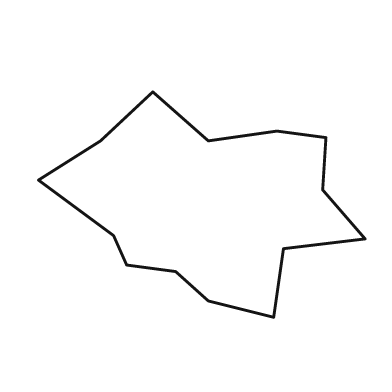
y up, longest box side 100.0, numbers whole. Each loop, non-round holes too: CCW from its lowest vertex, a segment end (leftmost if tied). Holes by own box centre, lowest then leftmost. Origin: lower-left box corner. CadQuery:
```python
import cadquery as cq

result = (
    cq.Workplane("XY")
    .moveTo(72.0, 0.0)
    .lineTo(75.0, 21.0)
    .lineTo(100.0, 24.0)
    .lineTo(87.0, 39.0)
    .lineTo(88.0, 55.0)
    .lineTo(73.0, 57.0)
    .lineTo(52.0, 54.0)
    .lineTo(35.0, 69.0)
    .lineTo(19.0, 54.0)
    .lineTo(0.0, 42.0)
    .lineTo(23.0, 25.0)
    .lineTo(27.0, 16.0)
    .lineTo(42.0, 14.0)
    .lineTo(52.0, 5.0)
    .close()
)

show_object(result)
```